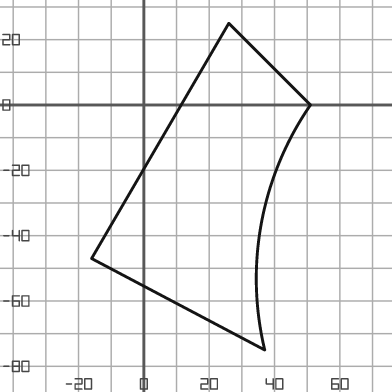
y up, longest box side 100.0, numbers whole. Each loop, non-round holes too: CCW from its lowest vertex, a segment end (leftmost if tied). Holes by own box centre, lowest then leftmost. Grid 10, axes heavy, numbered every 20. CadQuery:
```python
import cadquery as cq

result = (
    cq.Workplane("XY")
    .moveTo(37.0, -75.0)
    .threePointArc((36.0, -36.0), (51.0, 0.0))
    .lineTo(26.0, 25.0)
    .lineTo(-16.0, -47.0)
    .close()
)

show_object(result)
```